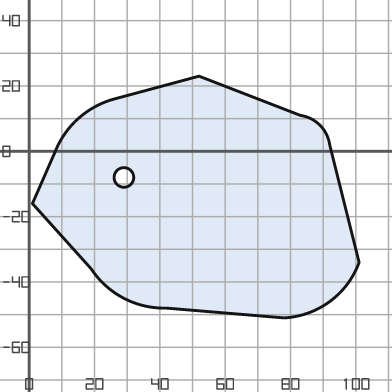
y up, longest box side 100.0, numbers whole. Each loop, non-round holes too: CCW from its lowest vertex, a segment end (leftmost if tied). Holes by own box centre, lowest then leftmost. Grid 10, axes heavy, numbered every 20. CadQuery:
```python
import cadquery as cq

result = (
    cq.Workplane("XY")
    .moveTo(78.0, -51.0)
    .threePointArc((92.0, -46.0), (101.0, -34.0))
    .lineTo(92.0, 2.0)
    .threePointArc((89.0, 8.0), (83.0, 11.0))
    .lineTo(52.0, 23.0)
    .lineTo(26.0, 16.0)
    .threePointArc((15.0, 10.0), (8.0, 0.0))
    .lineTo(1.0, -16.0)
    .lineTo(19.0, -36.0)
    .threePointArc((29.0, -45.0), (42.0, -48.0))
    .close()
    .moveTo(29.0, -8.0)
    .circle(3.0)
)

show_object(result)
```